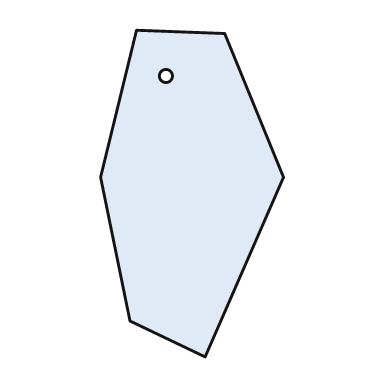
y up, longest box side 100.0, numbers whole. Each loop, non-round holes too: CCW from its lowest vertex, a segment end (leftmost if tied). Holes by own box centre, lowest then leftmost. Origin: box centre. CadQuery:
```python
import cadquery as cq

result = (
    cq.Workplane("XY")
    .moveTo(4.0, -50.0)
    .lineTo(28.0, 5.0)
    .lineTo(10.0, 49.0)
    .lineTo(-17.0, 50.0)
    .lineTo(-28.0, 5.0)
    .lineTo(-19.0, -39.0)
    .close()
    .moveTo(-8.0, 36.0)
    .circle(2.0)
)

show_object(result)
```